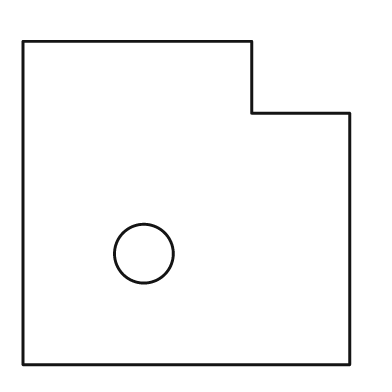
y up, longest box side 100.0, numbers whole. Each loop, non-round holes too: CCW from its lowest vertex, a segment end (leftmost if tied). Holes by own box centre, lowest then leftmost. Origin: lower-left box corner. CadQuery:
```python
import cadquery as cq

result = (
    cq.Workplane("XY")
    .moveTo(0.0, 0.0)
    .lineTo(100.0, 0.0)
    .lineTo(100.0, 77.0)
    .lineTo(70.0, 77.0)
    .lineTo(70.0, 99.0)
    .lineTo(0.0, 99.0)
    .close()
    .moveTo(37.0, 34.0)
    .circle(9.0)
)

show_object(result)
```